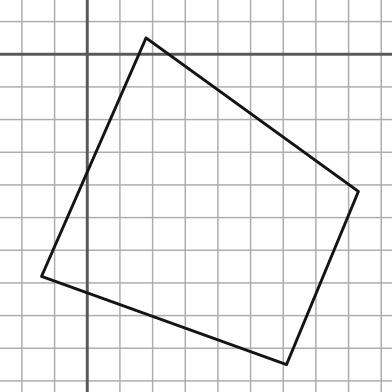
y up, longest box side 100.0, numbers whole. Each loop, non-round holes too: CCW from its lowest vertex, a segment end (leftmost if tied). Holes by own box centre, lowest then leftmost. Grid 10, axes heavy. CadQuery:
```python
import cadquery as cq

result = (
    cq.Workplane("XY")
    .moveTo(61.0, -95.0)
    .lineTo(83.0, -42.0)
    .lineTo(18.0, 5.0)
    .lineTo(-14.0, -68.0)
    .close()
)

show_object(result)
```